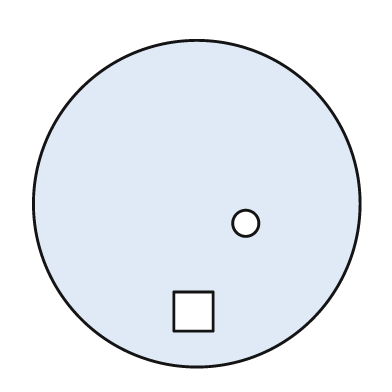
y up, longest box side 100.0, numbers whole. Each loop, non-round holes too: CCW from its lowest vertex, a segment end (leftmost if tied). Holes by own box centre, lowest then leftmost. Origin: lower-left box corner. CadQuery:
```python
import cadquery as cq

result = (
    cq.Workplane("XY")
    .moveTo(50.0, 50.0)
    .circle(50.0)
    .moveTo(43.0, 11.0)
    .lineTo(55.0, 11.0)
    .lineTo(55.0, 23.0)
    .lineTo(43.0, 23.0)
    .close()
    .moveTo(65.0, 44.0)
    .circle(4.0)
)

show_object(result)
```